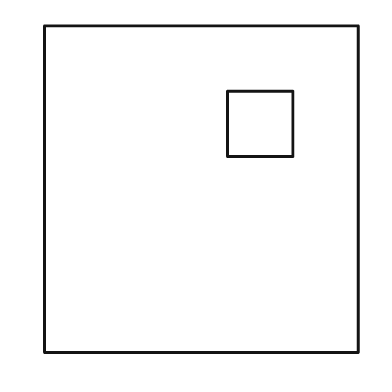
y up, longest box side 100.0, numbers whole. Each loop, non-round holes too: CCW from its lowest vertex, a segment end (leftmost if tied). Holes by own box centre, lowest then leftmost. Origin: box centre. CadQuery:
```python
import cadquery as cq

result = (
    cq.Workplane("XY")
    .moveTo(-48.0, -50.0)
    .lineTo(48.0, -50.0)
    .lineTo(48.0, 50.0)
    .lineTo(-48.0, 50.0)
    .close()
    .moveTo(8.0, 10.0)
    .lineTo(28.0, 10.0)
    .lineTo(28.0, 30.0)
    .lineTo(8.0, 30.0)
    .close()
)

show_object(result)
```